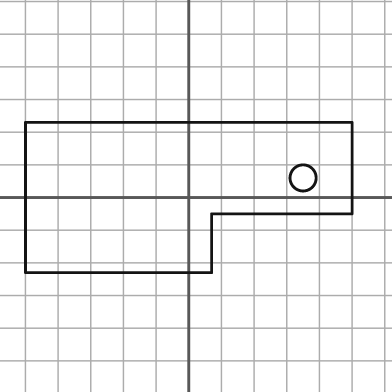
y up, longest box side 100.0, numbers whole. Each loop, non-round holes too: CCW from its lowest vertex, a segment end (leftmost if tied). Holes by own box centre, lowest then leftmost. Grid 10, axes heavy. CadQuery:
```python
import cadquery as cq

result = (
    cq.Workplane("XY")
    .moveTo(-50.0, -23.0)
    .lineTo(7.0, -23.0)
    .lineTo(7.0, -5.0)
    .lineTo(50.0, -5.0)
    .lineTo(50.0, 23.0)
    .lineTo(-50.0, 23.0)
    .close()
    .moveTo(35.0, 6.0)
    .circle(4.0)
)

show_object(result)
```